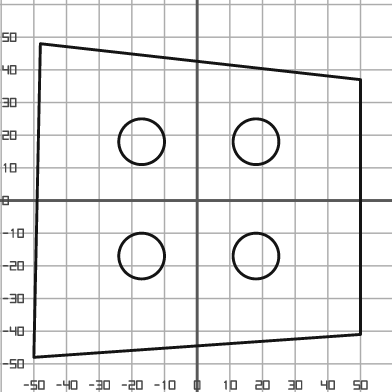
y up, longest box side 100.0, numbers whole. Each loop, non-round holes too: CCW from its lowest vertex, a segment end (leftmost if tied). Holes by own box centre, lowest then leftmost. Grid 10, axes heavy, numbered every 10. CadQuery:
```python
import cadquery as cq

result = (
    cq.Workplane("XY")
    .moveTo(-50.0, -48.0)
    .lineTo(50.0, -41.0)
    .lineTo(50.0, 37.0)
    .lineTo(-48.0, 48.0)
    .close()
    .moveTo(-17.0, -17.0)
    .circle(7.0)
    .moveTo(18.0, -17.0)
    .circle(7.0)
    .moveTo(-17.0, 18.0)
    .circle(7.0)
    .moveTo(18.0, 18.0)
    .circle(7.0)
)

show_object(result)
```